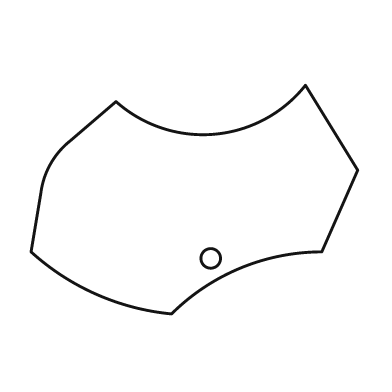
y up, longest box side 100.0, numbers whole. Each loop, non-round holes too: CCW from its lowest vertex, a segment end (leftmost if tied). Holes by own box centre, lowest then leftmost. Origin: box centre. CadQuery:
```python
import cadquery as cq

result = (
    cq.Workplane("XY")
    .moveTo(-7.0, -35.0)
    .threePointArc((14.0, -21.0), (39.0, -16.0))
    .lineTo(50.0, 9.0)
    .lineTo(34.0, 35.0)
    .threePointArc((6.0, 20.0), (-24.0, 30.0))
    .lineTo(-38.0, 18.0)
    .threePointArc((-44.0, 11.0), (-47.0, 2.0))
    .lineTo(-50.0, -16.0)
    .threePointArc((-30.0, -29.0), (-7.0, -35.0))
    .close()
    .moveTo(5.0, -18.0)
    .circle(3.0)
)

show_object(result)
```